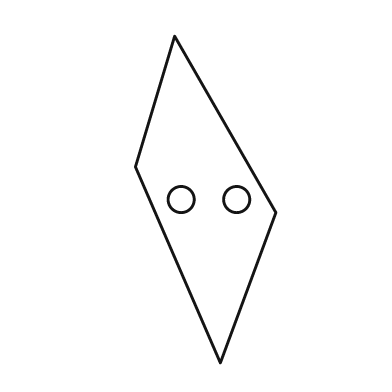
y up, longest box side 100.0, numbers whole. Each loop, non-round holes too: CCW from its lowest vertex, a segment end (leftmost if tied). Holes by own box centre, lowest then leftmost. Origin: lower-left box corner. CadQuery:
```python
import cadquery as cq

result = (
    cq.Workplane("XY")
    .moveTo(26.0, 0.0)
    .lineTo(43.0, 46.0)
    .lineTo(12.0, 100.0)
    .lineTo(0.0, 60.0)
    .close()
    .moveTo(14.0, 50.0)
    .circle(4.0)
    .moveTo(31.0, 50.0)
    .circle(4.0)
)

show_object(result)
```